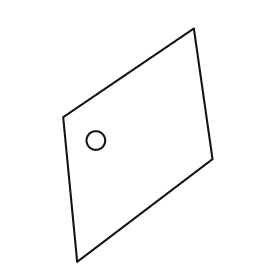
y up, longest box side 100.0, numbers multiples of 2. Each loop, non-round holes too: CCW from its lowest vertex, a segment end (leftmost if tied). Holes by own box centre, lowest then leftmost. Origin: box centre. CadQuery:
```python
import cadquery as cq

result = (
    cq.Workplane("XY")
    .moveTo(-26.0, -50.0)
    .lineTo(32.0, -6.0)
    .lineTo(24.0, 50.0)
    .lineTo(-32.0, 12.0)
    .close()
    .moveTo(-18.0, 2.0)
    .circle(4.0)
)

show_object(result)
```